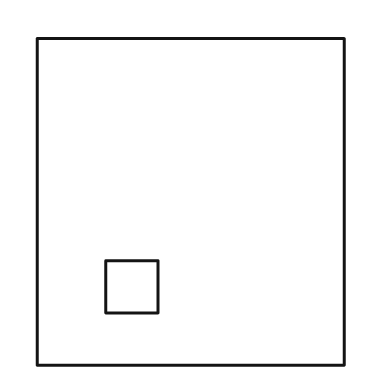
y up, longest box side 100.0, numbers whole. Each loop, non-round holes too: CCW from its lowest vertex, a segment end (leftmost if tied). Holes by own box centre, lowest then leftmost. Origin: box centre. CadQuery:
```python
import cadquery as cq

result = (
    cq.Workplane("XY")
    .moveTo(-47.0, -50.0)
    .lineTo(47.0, -50.0)
    .lineTo(47.0, 50.0)
    .lineTo(-47.0, 50.0)
    .close()
    .moveTo(-26.0, -34.0)
    .lineTo(-10.0, -34.0)
    .lineTo(-10.0, -18.0)
    .lineTo(-26.0, -18.0)
    .close()
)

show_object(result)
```